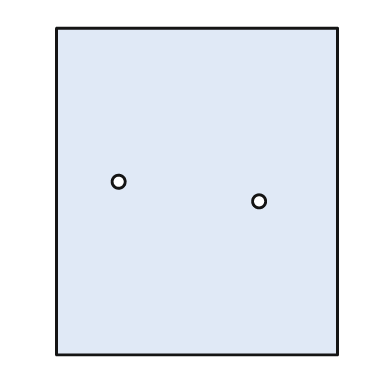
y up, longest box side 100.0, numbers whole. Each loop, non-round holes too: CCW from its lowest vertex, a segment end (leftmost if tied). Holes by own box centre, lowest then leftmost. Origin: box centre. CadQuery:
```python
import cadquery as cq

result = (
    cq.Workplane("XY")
    .moveTo(-43.0, -50.0)
    .lineTo(43.0, -50.0)
    .lineTo(43.0, 50.0)
    .lineTo(-43.0, 50.0)
    .close()
    .moveTo(19.0, -3.0)
    .circle(2.0)
    .moveTo(-24.0, 3.0)
    .circle(2.0)
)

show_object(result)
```